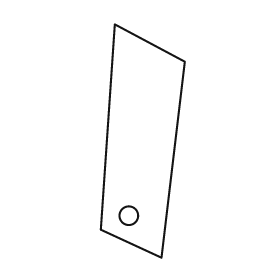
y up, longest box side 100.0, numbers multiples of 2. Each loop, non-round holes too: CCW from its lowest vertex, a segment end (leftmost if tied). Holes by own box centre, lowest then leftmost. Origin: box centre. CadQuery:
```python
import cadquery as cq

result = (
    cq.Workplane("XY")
    .moveTo(8.0, -50.0)
    .lineTo(18.0, 34.0)
    .lineTo(-12.0, 50.0)
    .lineTo(-18.0, -38.0)
    .close()
    .moveTo(-6.0, -32.0)
    .circle(4.0)
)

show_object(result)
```